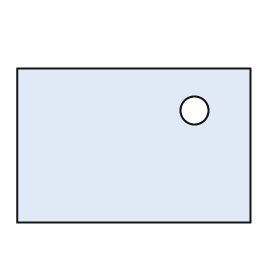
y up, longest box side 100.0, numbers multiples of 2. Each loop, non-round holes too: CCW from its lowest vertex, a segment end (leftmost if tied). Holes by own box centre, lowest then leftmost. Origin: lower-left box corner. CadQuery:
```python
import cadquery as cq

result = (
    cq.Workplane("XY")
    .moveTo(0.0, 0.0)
    .lineTo(100.0, 0.0)
    .lineTo(100.0, 66.0)
    .lineTo(0.0, 66.0)
    .close()
    .moveTo(76.0, 48.0)
    .circle(6.0)
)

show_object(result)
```